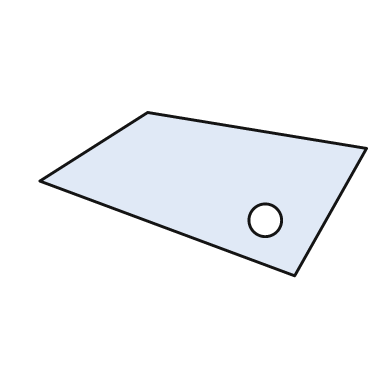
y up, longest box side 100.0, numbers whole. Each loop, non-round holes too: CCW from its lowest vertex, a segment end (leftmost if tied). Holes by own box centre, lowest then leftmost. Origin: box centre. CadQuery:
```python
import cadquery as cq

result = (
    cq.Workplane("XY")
    .moveTo(28.0, -25.0)
    .lineTo(50.0, 14.0)
    .lineTo(-17.0, 25.0)
    .lineTo(-50.0, 4.0)
    .close()
    .moveTo(19.0, -8.0)
    .circle(5.0)
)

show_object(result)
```